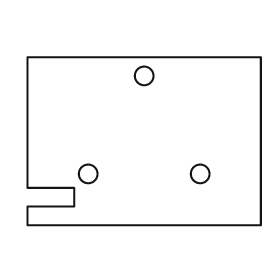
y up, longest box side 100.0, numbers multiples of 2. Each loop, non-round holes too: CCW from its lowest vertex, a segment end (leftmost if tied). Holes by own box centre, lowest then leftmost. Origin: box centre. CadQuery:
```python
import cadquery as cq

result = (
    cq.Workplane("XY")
    .moveTo(-50.0, -36.0)
    .lineTo(50.0, -36.0)
    .lineTo(50.0, 36.0)
    .lineTo(-50.0, 36.0)
    .lineTo(-50.0, -20.0)
    .lineTo(-30.0, -20.0)
    .lineTo(-30.0, -28.0)
    .lineTo(-50.0, -28.0)
    .close()
    .moveTo(-24.0, -14.0)
    .circle(4.0)
    .moveTo(24.0, -14.0)
    .circle(4.0)
    .moveTo(0.0, 28.0)
    .circle(4.0)
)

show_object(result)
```